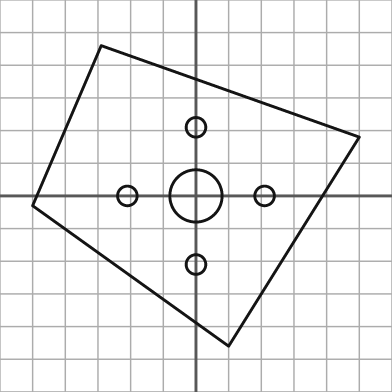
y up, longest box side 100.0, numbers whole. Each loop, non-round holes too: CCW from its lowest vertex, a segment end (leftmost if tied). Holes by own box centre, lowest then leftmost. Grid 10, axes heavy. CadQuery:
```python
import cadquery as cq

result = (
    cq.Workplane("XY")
    .moveTo(10.0, -46.0)
    .lineTo(50.0, 18.0)
    .lineTo(-29.0, 46.0)
    .lineTo(-50.0, -3.0)
    .close()
    .moveTo(0.0, -21.0)
    .circle(3.0)
    .moveTo(-21.0, 0.0)
    .circle(3.0)
    .moveTo(0.0, 0.0)
    .circle(8.0)
    .moveTo(21.0, 0.0)
    .circle(3.0)
    .moveTo(0.0, 21.0)
    .circle(3.0)
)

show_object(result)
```